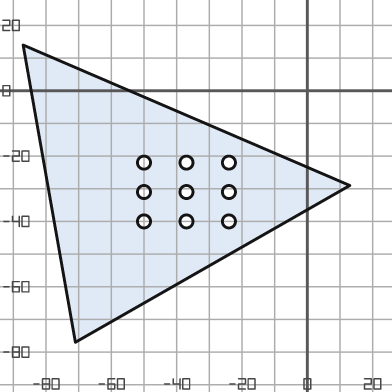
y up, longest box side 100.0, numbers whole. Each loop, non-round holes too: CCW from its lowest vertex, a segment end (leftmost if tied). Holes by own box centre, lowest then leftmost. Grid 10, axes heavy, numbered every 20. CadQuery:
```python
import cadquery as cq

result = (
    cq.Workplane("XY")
    .moveTo(-71.0, -77.0)
    .lineTo(13.0, -29.0)
    .lineTo(-87.0, 14.0)
    .close()
    .moveTo(-50.0, -40.0)
    .circle(2.0)
    .moveTo(-37.0, -40.0)
    .circle(2.0)
    .moveTo(-24.0, -40.0)
    .circle(2.0)
    .moveTo(-50.0, -31.0)
    .circle(2.0)
    .moveTo(-37.0, -31.0)
    .circle(2.0)
    .moveTo(-24.0, -31.0)
    .circle(2.0)
    .moveTo(-50.0, -22.0)
    .circle(2.0)
    .moveTo(-37.0, -22.0)
    .circle(2.0)
    .moveTo(-24.0, -22.0)
    .circle(2.0)
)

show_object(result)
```